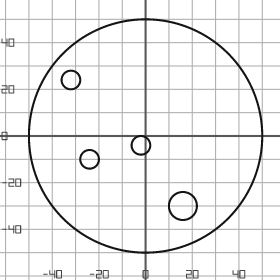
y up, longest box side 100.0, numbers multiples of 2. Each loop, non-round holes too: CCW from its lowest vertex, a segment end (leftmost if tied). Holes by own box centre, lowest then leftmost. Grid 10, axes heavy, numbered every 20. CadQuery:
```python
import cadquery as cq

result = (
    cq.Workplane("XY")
    .moveTo(0.0, 0.0)
    .circle(50.0)
    .moveTo(16.0, -30.0)
    .circle(6.0)
    .moveTo(-24.0, -10.0)
    .circle(4.0)
    .moveTo(-2.0, -4.0)
    .circle(4.0)
    .moveTo(-32.0, 24.0)
    .circle(4.0)
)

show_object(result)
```